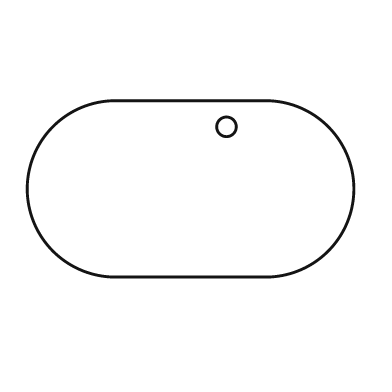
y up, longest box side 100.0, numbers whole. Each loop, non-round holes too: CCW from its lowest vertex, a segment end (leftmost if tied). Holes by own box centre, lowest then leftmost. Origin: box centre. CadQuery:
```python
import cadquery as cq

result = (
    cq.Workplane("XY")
    .moveTo(-23.0, -27.0)
    .lineTo(23.0, -27.0)
    .threePointArc((50.0, 0.0), (23.0, 27.0))
    .lineTo(-23.0, 27.0)
    .threePointArc((-50.0, 0.0), (-23.0, -27.0))
    .close()
    .moveTo(11.0, 19.0)
    .circle(3.0)
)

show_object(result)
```